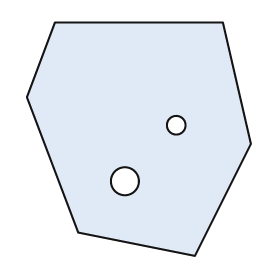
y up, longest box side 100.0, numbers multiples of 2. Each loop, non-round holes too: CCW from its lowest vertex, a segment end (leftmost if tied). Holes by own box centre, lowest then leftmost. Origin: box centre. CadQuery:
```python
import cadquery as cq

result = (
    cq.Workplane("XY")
    .moveTo(24.0, -50.0)
    .lineTo(48.0, -2.0)
    .lineTo(36.0, 50.0)
    .lineTo(-36.0, 50.0)
    .lineTo(-48.0, 18.0)
    .lineTo(-26.0, -40.0)
    .close()
    .moveTo(-6.0, -18.0)
    .circle(6.0)
    .moveTo(16.0, 6.0)
    .circle(4.0)
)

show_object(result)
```